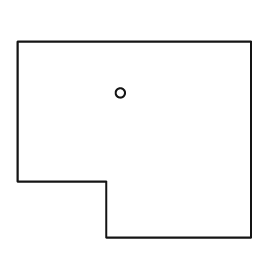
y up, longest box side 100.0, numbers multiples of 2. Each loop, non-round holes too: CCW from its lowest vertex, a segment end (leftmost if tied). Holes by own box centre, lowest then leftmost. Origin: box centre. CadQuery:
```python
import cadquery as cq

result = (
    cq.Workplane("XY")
    .moveTo(-12.0, -42.0)
    .lineTo(50.0, -42.0)
    .lineTo(50.0, 42.0)
    .lineTo(-50.0, 42.0)
    .lineTo(-50.0, -18.0)
    .lineTo(-12.0, -18.0)
    .close()
    .moveTo(-6.0, 20.0)
    .circle(2.0)
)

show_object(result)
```